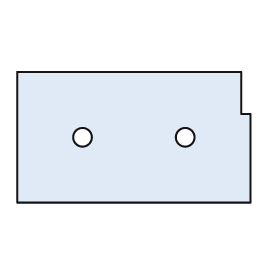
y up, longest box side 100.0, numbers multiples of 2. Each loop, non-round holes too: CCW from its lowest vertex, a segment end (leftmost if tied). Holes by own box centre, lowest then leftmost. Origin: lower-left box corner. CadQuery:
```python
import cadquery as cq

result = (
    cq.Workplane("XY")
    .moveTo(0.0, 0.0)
    .lineTo(100.0, 0.0)
    .lineTo(100.0, 38.0)
    .lineTo(96.0, 38.0)
    .lineTo(96.0, 56.0)
    .lineTo(0.0, 56.0)
    .close()
    .moveTo(28.0, 28.0)
    .circle(4.0)
    .moveTo(72.0, 28.0)
    .circle(4.0)
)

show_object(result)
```